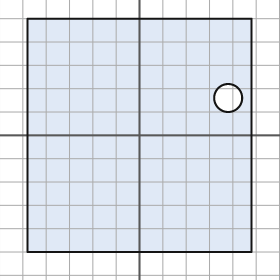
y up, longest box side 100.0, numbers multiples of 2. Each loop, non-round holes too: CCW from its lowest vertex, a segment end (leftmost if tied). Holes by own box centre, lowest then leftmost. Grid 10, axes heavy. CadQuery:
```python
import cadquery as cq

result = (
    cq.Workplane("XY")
    .moveTo(-48.0, -50.0)
    .lineTo(48.0, -50.0)
    .lineTo(48.0, 50.0)
    .lineTo(-48.0, 50.0)
    .close()
    .moveTo(38.0, 16.0)
    .circle(6.0)
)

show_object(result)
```